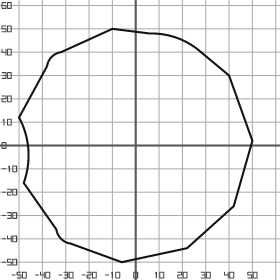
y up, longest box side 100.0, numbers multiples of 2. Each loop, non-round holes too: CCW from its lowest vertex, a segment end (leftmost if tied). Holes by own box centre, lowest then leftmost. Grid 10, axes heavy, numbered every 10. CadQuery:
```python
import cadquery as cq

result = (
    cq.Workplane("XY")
    .moveTo(-6.0, -50.0)
    .lineTo(22.0, -44.0)
    .lineTo(42.0, -26.0)
    .lineTo(50.0, 2.0)
    .lineTo(40.0, 30.0)
    .lineTo(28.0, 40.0)
    .threePointArc((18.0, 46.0), (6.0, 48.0))
    .lineTo(-10.0, 50.0)
    .lineTo(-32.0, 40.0)
    .threePointArc((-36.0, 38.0), (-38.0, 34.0))
    .lineTo(-50.0, 12.0)
    .threePointArc((-46.0, -2.0), (-48.0, -16.0))
    .lineTo(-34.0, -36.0)
    .threePointArc((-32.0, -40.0), (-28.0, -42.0))
    .close()
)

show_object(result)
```